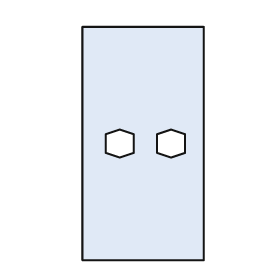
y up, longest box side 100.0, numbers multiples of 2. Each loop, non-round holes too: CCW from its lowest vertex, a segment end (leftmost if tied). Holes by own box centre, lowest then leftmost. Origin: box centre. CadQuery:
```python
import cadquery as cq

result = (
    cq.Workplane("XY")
    .moveTo(-26.0, -50.0)
    .lineTo(26.0, -50.0)
    .lineTo(26.0, 50.0)
    .lineTo(-26.0, 50.0)
    .close()
    .moveTo(-10.0, -6.0)
    .lineTo(-4.0, -4.0)
    .lineTo(-4.0, 4.0)
    .lineTo(-10.0, 6.0)
    .lineTo(-16.0, 4.0)
    .lineTo(-16.0, -4.0)
    .close()
    .moveTo(12.0, -6.0)
    .lineTo(18.0, -4.0)
    .lineTo(18.0, 4.0)
    .lineTo(12.0, 6.0)
    .lineTo(6.0, 4.0)
    .lineTo(6.0, -4.0)
    .close()
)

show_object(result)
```